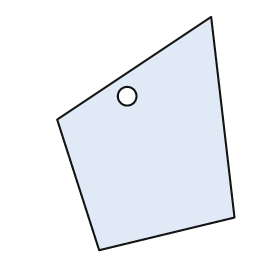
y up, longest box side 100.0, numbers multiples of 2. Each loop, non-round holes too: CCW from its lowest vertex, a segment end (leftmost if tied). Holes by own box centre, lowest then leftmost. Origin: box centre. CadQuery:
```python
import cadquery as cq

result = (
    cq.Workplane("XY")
    .moveTo(-20.0, -50.0)
    .lineTo(38.0, -36.0)
    .lineTo(28.0, 50.0)
    .lineTo(-38.0, 6.0)
    .close()
    .moveTo(-8.0, 16.0)
    .circle(4.0)
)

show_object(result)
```